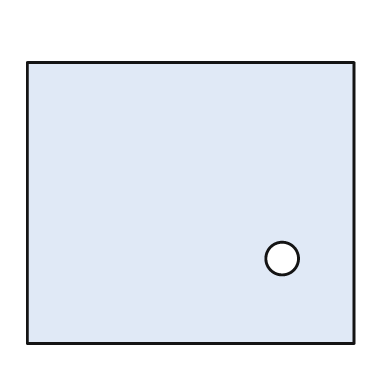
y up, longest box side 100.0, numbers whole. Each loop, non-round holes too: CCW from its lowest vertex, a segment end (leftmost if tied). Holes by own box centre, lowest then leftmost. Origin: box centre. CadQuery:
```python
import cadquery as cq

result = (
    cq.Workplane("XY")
    .moveTo(-50.0, -43.0)
    .lineTo(50.0, -43.0)
    .lineTo(50.0, 43.0)
    .lineTo(-50.0, 43.0)
    .close()
    .moveTo(28.0, -17.0)
    .circle(5.0)
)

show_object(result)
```